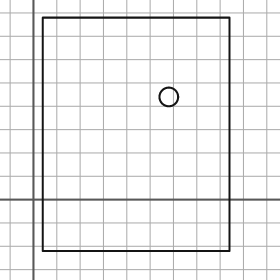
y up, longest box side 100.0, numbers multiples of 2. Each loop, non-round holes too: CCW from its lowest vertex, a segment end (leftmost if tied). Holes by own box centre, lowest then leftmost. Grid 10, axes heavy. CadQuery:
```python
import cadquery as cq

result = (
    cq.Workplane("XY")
    .moveTo(4.0, -22.0)
    .lineTo(84.0, -22.0)
    .lineTo(84.0, 78.0)
    .lineTo(4.0, 78.0)
    .close()
    .moveTo(58.0, 44.0)
    .circle(4.0)
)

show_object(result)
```